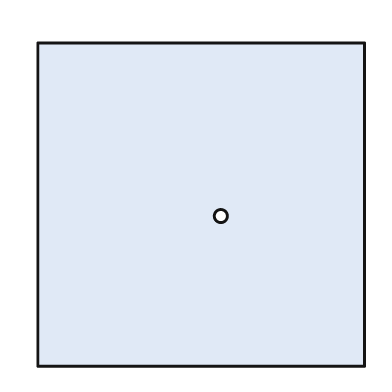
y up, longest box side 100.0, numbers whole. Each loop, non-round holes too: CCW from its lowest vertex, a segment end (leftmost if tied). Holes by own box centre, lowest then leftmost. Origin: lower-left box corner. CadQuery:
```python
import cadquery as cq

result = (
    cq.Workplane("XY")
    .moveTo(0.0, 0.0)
    .lineTo(100.0, 0.0)
    .lineTo(100.0, 99.0)
    .lineTo(0.0, 99.0)
    .close()
    .moveTo(56.0, 46.0)
    .circle(2.0)
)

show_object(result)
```